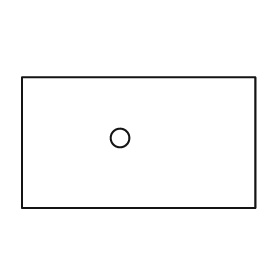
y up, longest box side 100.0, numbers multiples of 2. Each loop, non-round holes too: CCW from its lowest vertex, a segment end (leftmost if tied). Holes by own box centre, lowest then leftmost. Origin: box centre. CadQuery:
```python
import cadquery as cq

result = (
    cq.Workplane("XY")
    .moveTo(-50.0, -28.0)
    .lineTo(50.0, -28.0)
    .lineTo(50.0, 28.0)
    .lineTo(-50.0, 28.0)
    .close()
    .moveTo(-8.0, 2.0)
    .circle(4.0)
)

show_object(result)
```